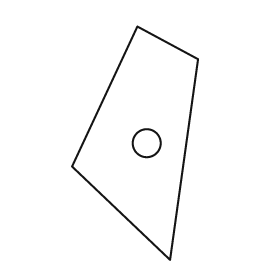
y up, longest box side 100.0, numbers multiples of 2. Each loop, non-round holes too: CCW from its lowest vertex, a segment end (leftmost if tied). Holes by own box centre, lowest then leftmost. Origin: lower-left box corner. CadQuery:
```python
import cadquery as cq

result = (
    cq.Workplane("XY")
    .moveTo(42.0, 0.0)
    .lineTo(54.0, 86.0)
    .lineTo(28.0, 100.0)
    .lineTo(0.0, 40.0)
    .close()
    .moveTo(32.0, 50.0)
    .circle(6.0)
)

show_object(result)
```